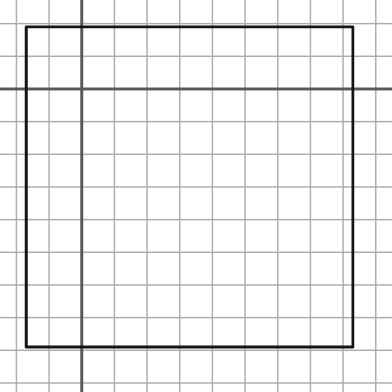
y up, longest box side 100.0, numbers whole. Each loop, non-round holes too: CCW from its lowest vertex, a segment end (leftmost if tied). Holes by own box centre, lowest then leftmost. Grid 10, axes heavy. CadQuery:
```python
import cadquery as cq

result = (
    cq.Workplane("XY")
    .moveTo(-17.0, -79.0)
    .lineTo(83.0, -79.0)
    .lineTo(83.0, 19.0)
    .lineTo(-17.0, 19.0)
    .close()
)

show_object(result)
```